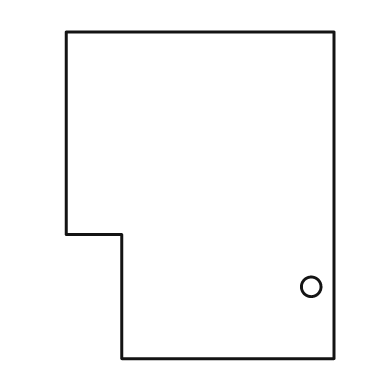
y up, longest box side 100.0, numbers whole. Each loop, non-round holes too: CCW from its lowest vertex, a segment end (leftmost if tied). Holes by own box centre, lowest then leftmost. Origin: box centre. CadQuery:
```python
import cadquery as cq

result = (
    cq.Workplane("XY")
    .moveTo(-24.0, -50.0)
    .lineTo(41.0, -50.0)
    .lineTo(41.0, 50.0)
    .lineTo(-41.0, 50.0)
    .lineTo(-41.0, -12.0)
    .lineTo(-24.0, -12.0)
    .close()
    .moveTo(34.0, -28.0)
    .circle(3.0)
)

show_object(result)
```